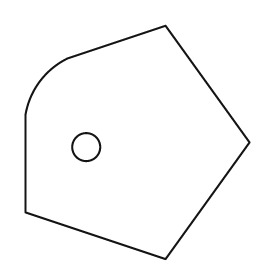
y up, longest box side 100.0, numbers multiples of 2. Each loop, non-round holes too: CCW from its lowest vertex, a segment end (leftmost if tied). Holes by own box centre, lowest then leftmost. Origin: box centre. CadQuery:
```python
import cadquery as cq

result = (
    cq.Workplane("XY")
    .moveTo(12.0, -50.0)
    .lineTo(48.0, 0.0)
    .lineTo(12.0, 50.0)
    .lineTo(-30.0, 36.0)
    .threePointArc((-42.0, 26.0), (-48.0, 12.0))
    .lineTo(-48.0, -30.0)
    .close()
    .moveTo(-22.0, -2.0)
    .circle(6.0)
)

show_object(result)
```